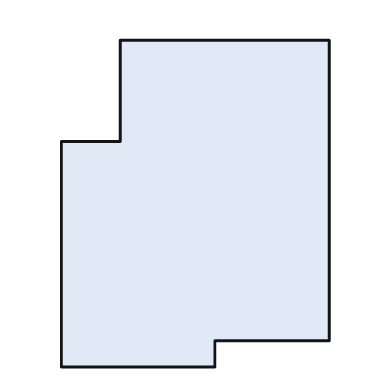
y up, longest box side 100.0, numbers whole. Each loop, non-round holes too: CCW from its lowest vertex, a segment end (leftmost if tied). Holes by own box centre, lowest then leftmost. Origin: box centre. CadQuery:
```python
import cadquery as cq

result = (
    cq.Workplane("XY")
    .moveTo(-41.0, -50.0)
    .lineTo(6.0, -50.0)
    .lineTo(6.0, -42.0)
    .lineTo(41.0, -42.0)
    .lineTo(41.0, 50.0)
    .lineTo(-23.0, 50.0)
    .lineTo(-23.0, 19.0)
    .lineTo(-41.0, 19.0)
    .close()
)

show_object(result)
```